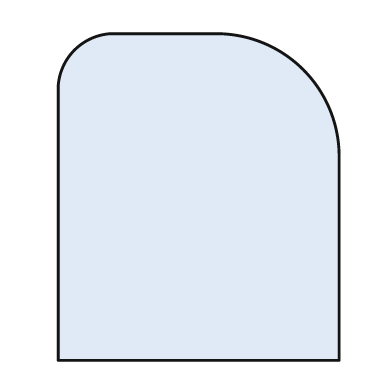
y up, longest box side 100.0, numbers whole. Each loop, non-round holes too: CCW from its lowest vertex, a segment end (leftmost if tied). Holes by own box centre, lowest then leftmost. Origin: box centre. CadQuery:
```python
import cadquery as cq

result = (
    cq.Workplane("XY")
    .moveTo(-43.0, -50.0)
    .lineTo(43.0, -50.0)
    .lineTo(43.0, 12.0)
    .threePointArc((32.0, 39.0), (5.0, 50.0))
    .lineTo(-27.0, 50.0)
    .threePointArc((-38.0, 45.0), (-43.0, 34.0))
    .close()
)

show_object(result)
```